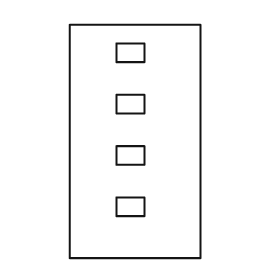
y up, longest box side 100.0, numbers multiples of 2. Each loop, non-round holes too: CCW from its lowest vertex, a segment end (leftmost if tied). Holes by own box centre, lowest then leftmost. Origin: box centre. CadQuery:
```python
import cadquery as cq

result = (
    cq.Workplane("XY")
    .moveTo(-28.0, -50.0)
    .lineTo(28.0, -50.0)
    .lineTo(28.0, 50.0)
    .lineTo(-28.0, 50.0)
    .close()
    .moveTo(-8.0, -32.0)
    .lineTo(4.0, -32.0)
    .lineTo(4.0, -24.0)
    .lineTo(-8.0, -24.0)
    .close()
    .moveTo(-8.0, -10.0)
    .lineTo(4.0, -10.0)
    .lineTo(4.0, -2.0)
    .lineTo(-8.0, -2.0)
    .close()
    .moveTo(-8.0, 12.0)
    .lineTo(4.0, 12.0)
    .lineTo(4.0, 20.0)
    .lineTo(-8.0, 20.0)
    .close()
    .moveTo(-8.0, 34.0)
    .lineTo(4.0, 34.0)
    .lineTo(4.0, 42.0)
    .lineTo(-8.0, 42.0)
    .close()
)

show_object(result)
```